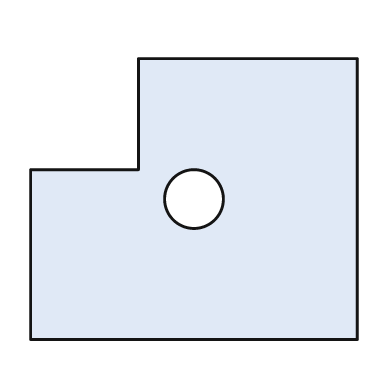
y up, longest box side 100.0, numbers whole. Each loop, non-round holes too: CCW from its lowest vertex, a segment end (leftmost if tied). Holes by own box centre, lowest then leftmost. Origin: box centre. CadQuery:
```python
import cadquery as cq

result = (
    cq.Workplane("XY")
    .moveTo(-50.0, -43.0)
    .lineTo(50.0, -43.0)
    .lineTo(50.0, 43.0)
    .lineTo(-17.0, 43.0)
    .lineTo(-17.0, 9.0)
    .lineTo(-50.0, 9.0)
    .close()
    .moveTo(0.0, 0.0)
    .circle(9.0)
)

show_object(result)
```